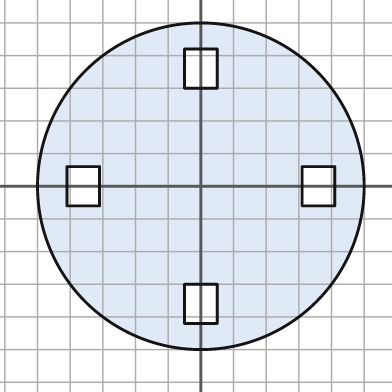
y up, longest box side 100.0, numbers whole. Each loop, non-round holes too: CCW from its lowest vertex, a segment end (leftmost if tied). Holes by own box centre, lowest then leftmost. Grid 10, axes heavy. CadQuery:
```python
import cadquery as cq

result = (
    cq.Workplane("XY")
    .moveTo(0.0, 0.0)
    .circle(50.0)
    .moveTo(-5.0, -42.0)
    .lineTo(5.0, -42.0)
    .lineTo(5.0, -30.0)
    .lineTo(-5.0, -30.0)
    .close()
    .moveTo(-41.0, -6.0)
    .lineTo(-31.0, -6.0)
    .lineTo(-31.0, 6.0)
    .lineTo(-41.0, 6.0)
    .close()
    .moveTo(31.0, -6.0)
    .lineTo(41.0, -6.0)
    .lineTo(41.0, 6.0)
    .lineTo(31.0, 6.0)
    .close()
    .moveTo(-5.0, 30.0)
    .lineTo(5.0, 30.0)
    .lineTo(5.0, 42.0)
    .lineTo(-5.0, 42.0)
    .close()
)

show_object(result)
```